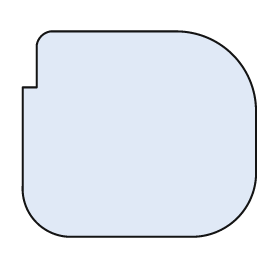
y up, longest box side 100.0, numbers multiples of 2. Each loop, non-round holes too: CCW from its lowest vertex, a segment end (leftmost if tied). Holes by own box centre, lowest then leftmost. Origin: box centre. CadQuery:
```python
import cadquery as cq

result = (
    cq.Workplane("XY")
    .moveTo(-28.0, -44.0)
    .lineTo(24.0, -44.0)
    .threePointArc((42.0, -36.0), (50.0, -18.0))
    .lineTo(50.0, 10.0)
    .threePointArc((40.0, 34.0), (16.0, 44.0))
    .lineTo(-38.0, 44.0)
    .threePointArc((-42.0, 42.0), (-44.0, 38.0))
    .lineTo(-44.0, 20.0)
    .lineTo(-50.0, 20.0)
    .lineTo(-50.0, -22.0)
    .threePointArc((-44.0, -38.0), (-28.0, -44.0))
    .close()
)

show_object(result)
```